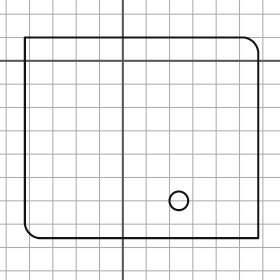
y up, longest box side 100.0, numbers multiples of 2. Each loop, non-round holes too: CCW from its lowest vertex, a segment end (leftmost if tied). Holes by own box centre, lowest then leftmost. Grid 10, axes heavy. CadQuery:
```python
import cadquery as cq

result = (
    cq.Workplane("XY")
    .moveTo(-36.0, -76.0)
    .lineTo(58.0, -76.0)
    .lineTo(58.0, 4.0)
    .threePointArc((56.0, 8.0), (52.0, 10.0))
    .lineTo(-42.0, 10.0)
    .lineTo(-42.0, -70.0)
    .threePointArc((-40.0, -74.0), (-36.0, -76.0))
    .close()
    .moveTo(24.0, -60.0)
    .circle(4.0)
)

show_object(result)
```